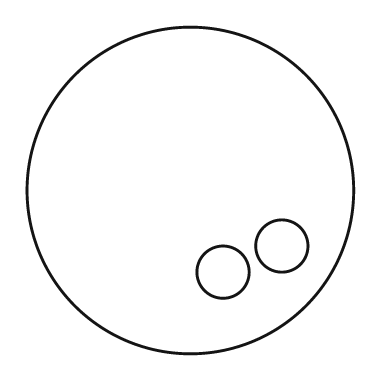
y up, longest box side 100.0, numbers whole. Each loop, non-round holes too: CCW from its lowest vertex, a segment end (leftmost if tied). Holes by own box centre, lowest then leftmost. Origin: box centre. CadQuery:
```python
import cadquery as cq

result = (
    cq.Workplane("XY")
    .moveTo(0.0, 0.0)
    .circle(50.0)
    .moveTo(10.0, -25.0)
    .circle(8.0)
    .moveTo(28.0, -17.0)
    .circle(8.0)
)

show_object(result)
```